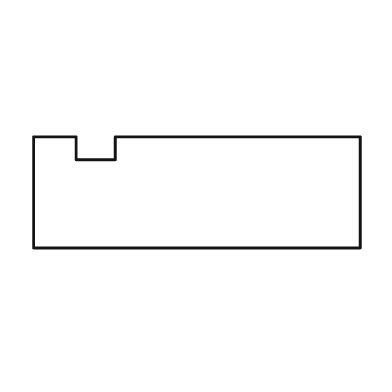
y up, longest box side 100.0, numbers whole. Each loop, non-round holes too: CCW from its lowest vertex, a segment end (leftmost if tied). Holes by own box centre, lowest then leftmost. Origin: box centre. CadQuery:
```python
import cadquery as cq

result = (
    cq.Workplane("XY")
    .moveTo(-50.0, -17.0)
    .lineTo(50.0, -17.0)
    .lineTo(50.0, 17.0)
    .lineTo(-25.0, 17.0)
    .lineTo(-25.0, 10.0)
    .lineTo(-37.0, 10.0)
    .lineTo(-37.0, 17.0)
    .lineTo(-50.0, 17.0)
    .close()
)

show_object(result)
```